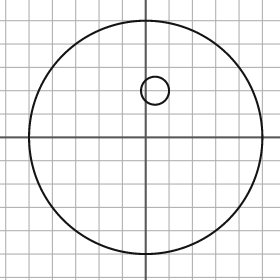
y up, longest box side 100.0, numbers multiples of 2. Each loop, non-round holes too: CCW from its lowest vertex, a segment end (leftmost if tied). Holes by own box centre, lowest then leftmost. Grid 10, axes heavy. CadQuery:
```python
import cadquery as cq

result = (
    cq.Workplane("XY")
    .moveTo(0.0, 0.0)
    .circle(50.0)
    .moveTo(4.0, 20.0)
    .circle(6.0)
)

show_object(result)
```